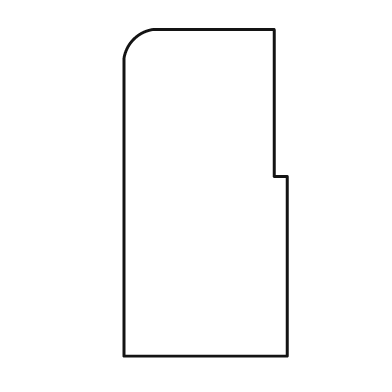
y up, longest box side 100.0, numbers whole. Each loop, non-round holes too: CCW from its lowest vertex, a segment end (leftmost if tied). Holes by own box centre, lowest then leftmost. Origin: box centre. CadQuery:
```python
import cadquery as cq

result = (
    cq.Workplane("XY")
    .moveTo(-25.0, -50.0)
    .lineTo(25.0, -50.0)
    .lineTo(25.0, 5.0)
    .lineTo(21.0, 5.0)
    .lineTo(21.0, 50.0)
    .lineTo(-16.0, 50.0)
    .threePointArc((-22.0, 47.0), (-25.0, 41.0))
    .close()
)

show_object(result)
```